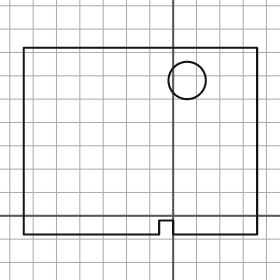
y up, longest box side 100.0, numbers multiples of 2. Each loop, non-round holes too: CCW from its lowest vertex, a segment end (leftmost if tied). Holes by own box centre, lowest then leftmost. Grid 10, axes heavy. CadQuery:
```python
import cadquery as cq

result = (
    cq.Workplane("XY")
    .moveTo(-64.0, -8.0)
    .lineTo(-6.0, -8.0)
    .lineTo(-6.0, -2.0)
    .lineTo(0.0, -2.0)
    .lineTo(0.0, -8.0)
    .lineTo(36.0, -8.0)
    .lineTo(36.0, 72.0)
    .lineTo(-64.0, 72.0)
    .close()
    .moveTo(6.0, 58.0)
    .circle(8.0)
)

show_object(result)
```